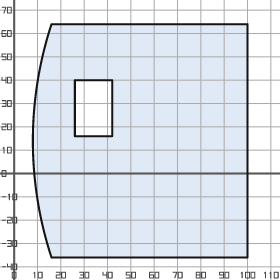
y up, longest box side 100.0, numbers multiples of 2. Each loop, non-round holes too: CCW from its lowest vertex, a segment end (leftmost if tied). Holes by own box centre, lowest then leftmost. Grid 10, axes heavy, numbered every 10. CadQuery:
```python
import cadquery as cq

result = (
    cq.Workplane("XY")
    .moveTo(16.0, -36.0)
    .lineTo(100.0, -36.0)
    .lineTo(100.0, 64.0)
    .lineTo(16.0, 64.0)
    .threePointArc((8.0, 14.0), (16.0, -36.0))
    .close()
    .moveTo(26.0, 16.0)
    .lineTo(42.0, 16.0)
    .lineTo(42.0, 40.0)
    .lineTo(26.0, 40.0)
    .close()
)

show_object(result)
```